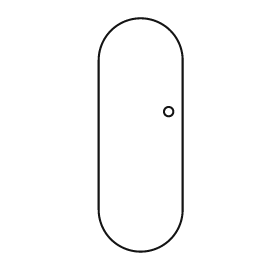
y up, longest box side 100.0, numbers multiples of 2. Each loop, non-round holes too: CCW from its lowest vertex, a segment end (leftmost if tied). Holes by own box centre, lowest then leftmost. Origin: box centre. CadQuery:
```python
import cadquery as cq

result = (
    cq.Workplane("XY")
    .moveTo(-18.0, -32.0)
    .threePointArc((0.0, -50.0), (18.0, -32.0))
    .lineTo(18.0, 32.0)
    .threePointArc((0.0, 50.0), (-18.0, 32.0))
    .close()
    .moveTo(12.0, 10.0)
    .circle(2.0)
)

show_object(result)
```